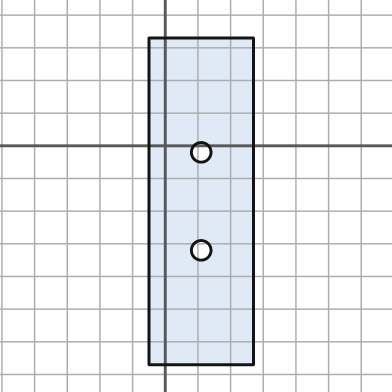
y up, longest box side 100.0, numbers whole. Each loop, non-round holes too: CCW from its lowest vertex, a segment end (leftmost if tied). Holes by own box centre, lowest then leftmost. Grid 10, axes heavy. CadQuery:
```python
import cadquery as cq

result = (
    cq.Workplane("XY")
    .moveTo(-5.0, -67.0)
    .lineTo(27.0, -67.0)
    .lineTo(27.0, 33.0)
    .lineTo(-5.0, 33.0)
    .close()
    .moveTo(11.0, -32.0)
    .circle(3.0)
    .moveTo(11.0, -2.0)
    .circle(3.0)
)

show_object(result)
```